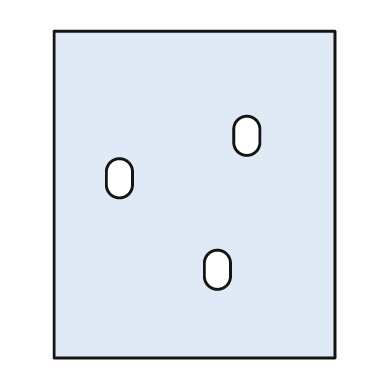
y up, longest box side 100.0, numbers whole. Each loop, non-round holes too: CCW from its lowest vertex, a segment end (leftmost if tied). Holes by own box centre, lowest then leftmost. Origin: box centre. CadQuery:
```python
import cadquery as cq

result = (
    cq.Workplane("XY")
    .moveTo(-43.0, -50.0)
    .lineTo(43.0, -50.0)
    .lineTo(43.0, 50.0)
    .lineTo(-43.0, 50.0)
    .close()
    .moveTo(3.0, -25.0)
    .threePointArc((7.0, -29.0), (11.0, -25.0))
    .lineTo(11.0, -21.0)
    .threePointArc((7.0, -17.0), (3.0, -21.0))
    .close()
    .moveTo(-27.0, 3.0)
    .threePointArc((-23.0, -1.0), (-19.0, 3.0))
    .lineTo(-19.0, 7.0)
    .threePointArc((-23.0, 11.0), (-27.0, 7.0))
    .close()
    .moveTo(12.0, 16.0)
    .threePointArc((16.0, 12.0), (20.0, 16.0))
    .lineTo(20.0, 20.0)
    .threePointArc((16.0, 24.0), (12.0, 20.0))
    .close()
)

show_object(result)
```